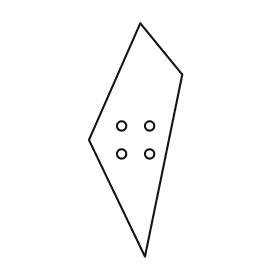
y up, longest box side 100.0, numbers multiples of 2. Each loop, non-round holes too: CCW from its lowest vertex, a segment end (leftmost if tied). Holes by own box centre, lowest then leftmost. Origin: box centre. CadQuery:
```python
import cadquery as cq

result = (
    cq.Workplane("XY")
    .moveTo(4.0, -50.0)
    .lineTo(20.0, 28.0)
    .lineTo(2.0, 50.0)
    .lineTo(-20.0, 0.0)
    .close()
    .moveTo(-6.0, -6.0)
    .circle(2.0)
    .moveTo(6.0, -6.0)
    .circle(2.0)
    .moveTo(-6.0, 6.0)
    .circle(2.0)
    .moveTo(6.0, 6.0)
    .circle(2.0)
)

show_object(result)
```